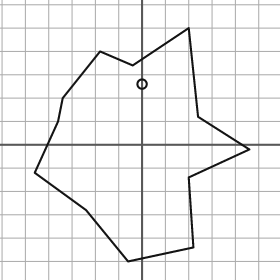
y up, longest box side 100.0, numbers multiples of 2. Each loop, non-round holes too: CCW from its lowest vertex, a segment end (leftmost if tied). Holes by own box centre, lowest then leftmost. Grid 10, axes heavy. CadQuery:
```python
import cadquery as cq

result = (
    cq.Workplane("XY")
    .moveTo(-6.0, -50.0)
    .lineTo(22.0, -44.0)
    .lineTo(20.0, -14.0)
    .lineTo(46.0, -2.0)
    .lineTo(24.0, 12.0)
    .lineTo(20.0, 50.0)
    .lineTo(-4.0, 34.0)
    .lineTo(-18.0, 40.0)
    .lineTo(-34.0, 20.0)
    .lineTo(-36.0, 10.0)
    .lineTo(-46.0, -12.0)
    .lineTo(-24.0, -28.0)
    .close()
    .moveTo(0.0, 26.0)
    .circle(2.0)
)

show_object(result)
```